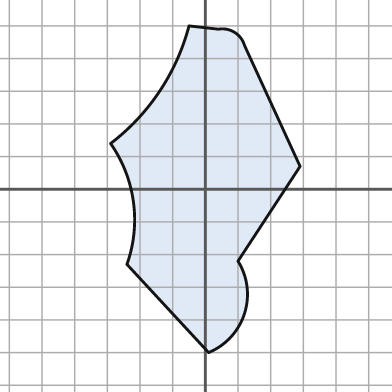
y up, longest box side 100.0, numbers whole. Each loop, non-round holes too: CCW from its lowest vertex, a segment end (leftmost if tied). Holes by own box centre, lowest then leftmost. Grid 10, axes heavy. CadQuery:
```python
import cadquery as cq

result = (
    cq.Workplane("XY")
    .moveTo(1.0, -50.0)
    .threePointArc((12.0, -38.0), (10.0, -22.0))
    .lineTo(29.0, 7.0)
    .lineTo(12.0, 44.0)
    .threePointArc((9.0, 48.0), (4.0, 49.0))
    .lineTo(-5.0, 50.0)
    .threePointArc((-14.0, 30.0), (-29.0, 14.0))
    .threePointArc((-22.0, -4.0), (-24.0, -23.0))
    .close()
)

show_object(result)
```